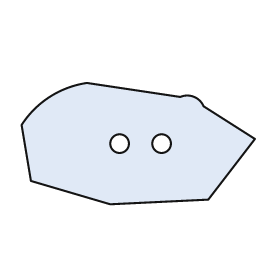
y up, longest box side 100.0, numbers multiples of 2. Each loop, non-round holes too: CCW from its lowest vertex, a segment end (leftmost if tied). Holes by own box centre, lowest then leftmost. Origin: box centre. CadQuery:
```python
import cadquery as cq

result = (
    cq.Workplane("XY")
    .moveTo(-12.0, -26.0)
    .lineTo(30.0, -24.0)
    .lineTo(50.0, 2.0)
    .lineTo(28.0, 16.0)
    .threePointArc((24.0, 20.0), (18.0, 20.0))
    .lineTo(-22.0, 26.0)
    .threePointArc((-38.0, 20.0), (-50.0, 8.0))
    .lineTo(-46.0, -16.0)
    .close()
    .moveTo(-8.0, 0.0)
    .circle(4.0)
    .moveTo(10.0, 0.0)
    .circle(4.0)
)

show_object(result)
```